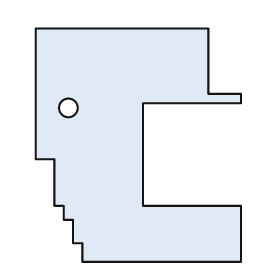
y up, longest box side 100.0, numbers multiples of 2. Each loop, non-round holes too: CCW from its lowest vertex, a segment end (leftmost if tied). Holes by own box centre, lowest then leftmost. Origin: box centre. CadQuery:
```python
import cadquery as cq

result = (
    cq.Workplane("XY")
    .moveTo(-24.0, -50.0)
    .lineTo(44.0, -50.0)
    .lineTo(44.0, -26.0)
    .lineTo(2.0, -26.0)
    .lineTo(2.0, 18.0)
    .lineTo(44.0, 18.0)
    .lineTo(44.0, 22.0)
    .lineTo(30.0, 22.0)
    .lineTo(30.0, 50.0)
    .lineTo(-44.0, 50.0)
    .lineTo(-44.0, -6.0)
    .lineTo(-36.0, -6.0)
    .lineTo(-36.0, -26.0)
    .lineTo(-32.0, -26.0)
    .lineTo(-32.0, -32.0)
    .lineTo(-28.0, -32.0)
    .lineTo(-28.0, -42.0)
    .lineTo(-24.0, -42.0)
    .close()
    .moveTo(-30.0, 16.0)
    .circle(4.0)
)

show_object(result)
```